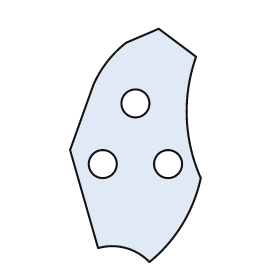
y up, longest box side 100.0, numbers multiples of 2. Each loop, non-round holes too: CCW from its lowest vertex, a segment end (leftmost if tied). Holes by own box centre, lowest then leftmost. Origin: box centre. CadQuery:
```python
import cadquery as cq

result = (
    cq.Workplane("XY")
    .moveTo(6.0, -50.0)
    .threePointArc((20.0, -34.0), (28.0, -14.0))
    .threePointArc((22.0, 12.0), (26.0, 38.0))
    .lineTo(10.0, 50.0)
    .lineTo(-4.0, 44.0)
    .threePointArc((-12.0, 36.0), (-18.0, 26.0))
    .lineTo(-28.0, -2.0)
    .lineTo(-16.0, -44.0)
    .threePointArc((-4.0, -44.0), (6.0, -50.0))
    .close()
    .moveTo(-14.0, -8.0)
    .circle(6.0)
    .moveTo(14.0, -8.0)
    .circle(6.0)
    .moveTo(0.0, 18.0)
    .circle(6.0)
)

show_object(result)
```